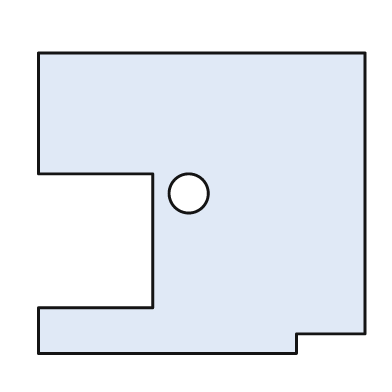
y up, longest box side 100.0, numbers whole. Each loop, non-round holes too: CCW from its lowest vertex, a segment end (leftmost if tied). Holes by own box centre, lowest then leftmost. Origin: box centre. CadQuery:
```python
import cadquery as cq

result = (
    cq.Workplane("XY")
    .moveTo(-50.0, -46.0)
    .lineTo(29.0, -46.0)
    .lineTo(29.0, -40.0)
    .lineTo(50.0, -40.0)
    .lineTo(50.0, 46.0)
    .lineTo(-50.0, 46.0)
    .lineTo(-50.0, 9.0)
    .lineTo(-15.0, 9.0)
    .lineTo(-15.0, -32.0)
    .lineTo(-50.0, -32.0)
    .close()
    .moveTo(-4.0, 3.0)
    .circle(6.0)
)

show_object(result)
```